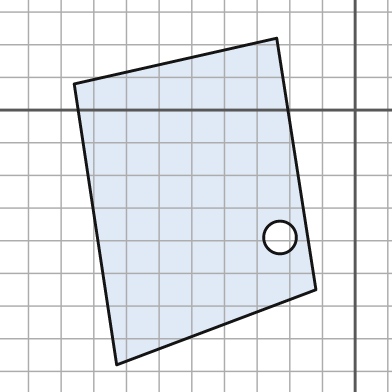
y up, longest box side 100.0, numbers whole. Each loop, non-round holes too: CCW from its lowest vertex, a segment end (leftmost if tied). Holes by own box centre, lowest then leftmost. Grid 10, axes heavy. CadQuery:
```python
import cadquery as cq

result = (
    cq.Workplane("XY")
    .moveTo(-73.0, -78.0)
    .lineTo(-12.0, -55.0)
    .lineTo(-24.0, 22.0)
    .lineTo(-86.0, 8.0)
    .close()
    .moveTo(-23.0, -39.0)
    .circle(5.0)
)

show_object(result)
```